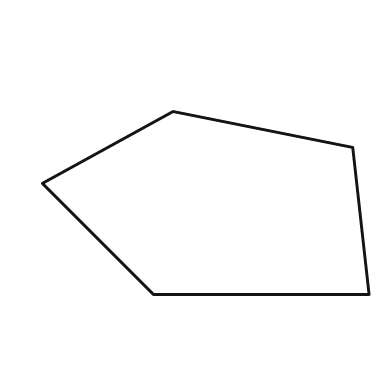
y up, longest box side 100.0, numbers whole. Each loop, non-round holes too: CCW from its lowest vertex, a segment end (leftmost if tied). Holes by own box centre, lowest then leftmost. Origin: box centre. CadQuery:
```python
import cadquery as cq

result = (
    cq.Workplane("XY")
    .moveTo(-16.0, -28.0)
    .lineTo(50.0, -28.0)
    .lineTo(45.0, 17.0)
    .lineTo(-10.0, 28.0)
    .lineTo(-50.0, 6.0)
    .close()
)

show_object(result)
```